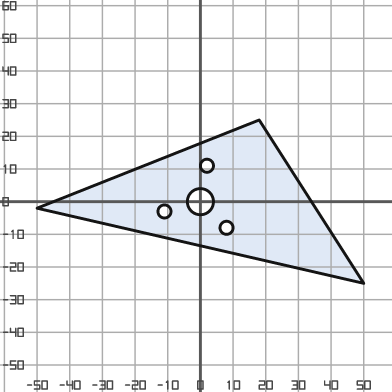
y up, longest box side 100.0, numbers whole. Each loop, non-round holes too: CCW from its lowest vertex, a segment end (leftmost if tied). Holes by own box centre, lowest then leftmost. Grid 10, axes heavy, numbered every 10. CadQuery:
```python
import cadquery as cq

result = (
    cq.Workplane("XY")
    .moveTo(50.0, -25.0)
    .lineTo(18.0, 25.0)
    .lineTo(-50.0, -2.0)
    .close()
    .moveTo(8.0, -8.0)
    .circle(2.0)
    .moveTo(-11.0, -3.0)
    .circle(2.0)
    .moveTo(0.0, 0.0)
    .circle(4.0)
    .moveTo(2.0, 11.0)
    .circle(2.0)
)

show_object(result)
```